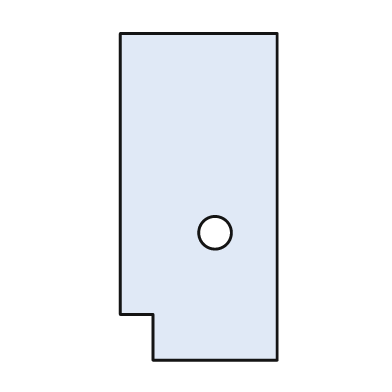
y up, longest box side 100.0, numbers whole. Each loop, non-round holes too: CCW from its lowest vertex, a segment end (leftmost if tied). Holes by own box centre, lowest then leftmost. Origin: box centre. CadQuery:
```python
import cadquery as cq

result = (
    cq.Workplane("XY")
    .moveTo(-14.0, -50.0)
    .lineTo(24.0, -50.0)
    .lineTo(24.0, 50.0)
    .lineTo(-24.0, 50.0)
    .lineTo(-24.0, -36.0)
    .lineTo(-14.0, -36.0)
    .close()
    .moveTo(5.0, -11.0)
    .circle(5.0)
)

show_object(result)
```